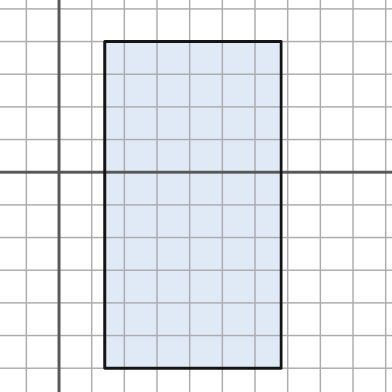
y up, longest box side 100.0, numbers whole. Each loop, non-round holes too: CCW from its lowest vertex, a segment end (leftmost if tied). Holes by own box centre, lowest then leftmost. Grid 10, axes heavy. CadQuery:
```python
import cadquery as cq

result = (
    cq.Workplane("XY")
    .moveTo(14.0, -60.0)
    .lineTo(68.0, -60.0)
    .lineTo(68.0, 40.0)
    .lineTo(14.0, 40.0)
    .close()
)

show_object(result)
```